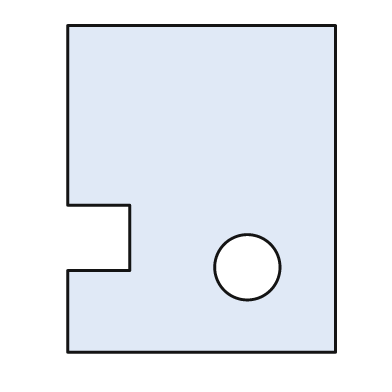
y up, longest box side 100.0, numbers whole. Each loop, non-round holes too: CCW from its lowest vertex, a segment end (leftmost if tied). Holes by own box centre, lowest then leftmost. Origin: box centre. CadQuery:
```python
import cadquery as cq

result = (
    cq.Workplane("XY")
    .moveTo(-41.0, -50.0)
    .lineTo(41.0, -50.0)
    .lineTo(41.0, 50.0)
    .lineTo(-41.0, 50.0)
    .lineTo(-41.0, -5.0)
    .lineTo(-22.0, -5.0)
    .lineTo(-22.0, -25.0)
    .lineTo(-41.0, -25.0)
    .close()
    .moveTo(14.0, -24.0)
    .circle(10.0)
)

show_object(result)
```